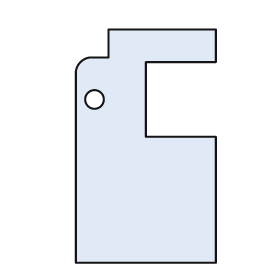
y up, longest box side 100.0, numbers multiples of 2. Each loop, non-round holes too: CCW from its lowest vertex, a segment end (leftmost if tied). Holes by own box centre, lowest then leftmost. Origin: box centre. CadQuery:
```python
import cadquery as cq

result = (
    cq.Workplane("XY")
    .moveTo(-30.0, -50.0)
    .lineTo(30.0, -50.0)
    .lineTo(30.0, 4.0)
    .lineTo(0.0, 4.0)
    .lineTo(0.0, 36.0)
    .lineTo(30.0, 36.0)
    .lineTo(30.0, 50.0)
    .lineTo(-16.0, 50.0)
    .lineTo(-16.0, 38.0)
    .lineTo(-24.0, 38.0)
    .threePointArc((-28.0, 36.0), (-30.0, 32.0))
    .close()
    .moveTo(-22.0, 20.0)
    .circle(4.0)
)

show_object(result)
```